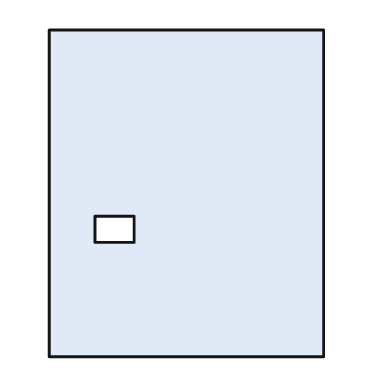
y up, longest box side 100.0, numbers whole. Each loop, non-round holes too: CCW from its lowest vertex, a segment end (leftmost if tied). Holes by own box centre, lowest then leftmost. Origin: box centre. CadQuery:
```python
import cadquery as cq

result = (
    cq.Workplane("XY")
    .moveTo(-42.0, -50.0)
    .lineTo(42.0, -50.0)
    .lineTo(42.0, 50.0)
    .lineTo(-42.0, 50.0)
    .close()
    .moveTo(-28.0, -15.0)
    .lineTo(-16.0, -15.0)
    .lineTo(-16.0, -7.0)
    .lineTo(-28.0, -7.0)
    .close()
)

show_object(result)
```